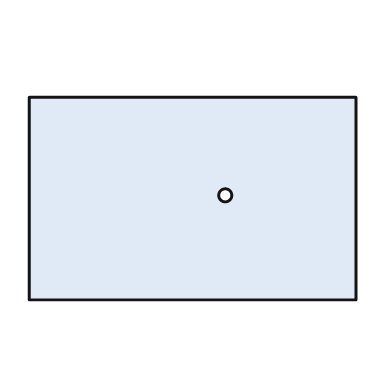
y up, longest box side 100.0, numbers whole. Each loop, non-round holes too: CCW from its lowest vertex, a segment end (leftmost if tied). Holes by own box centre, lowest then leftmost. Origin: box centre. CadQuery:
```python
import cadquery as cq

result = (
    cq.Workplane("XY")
    .moveTo(-50.0, -31.0)
    .lineTo(50.0, -31.0)
    .lineTo(50.0, 31.0)
    .lineTo(-50.0, 31.0)
    .close()
    .moveTo(10.0, 1.0)
    .circle(2.0)
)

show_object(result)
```